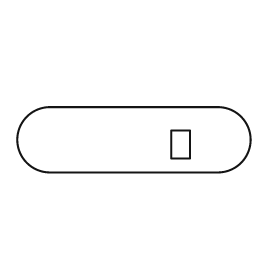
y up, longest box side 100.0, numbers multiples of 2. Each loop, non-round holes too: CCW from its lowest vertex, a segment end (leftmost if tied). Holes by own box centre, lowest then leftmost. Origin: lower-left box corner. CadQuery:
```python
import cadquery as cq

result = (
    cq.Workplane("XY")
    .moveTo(14.0, 0.0)
    .lineTo(86.0, 0.0)
    .threePointArc((100.0, 14.0), (86.0, 28.0))
    .lineTo(14.0, 28.0)
    .threePointArc((0.0, 14.0), (14.0, 0.0))
    .close()
    .moveTo(66.0, 6.0)
    .lineTo(74.0, 6.0)
    .lineTo(74.0, 18.0)
    .lineTo(66.0, 18.0)
    .close()
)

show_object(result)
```